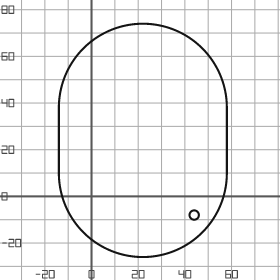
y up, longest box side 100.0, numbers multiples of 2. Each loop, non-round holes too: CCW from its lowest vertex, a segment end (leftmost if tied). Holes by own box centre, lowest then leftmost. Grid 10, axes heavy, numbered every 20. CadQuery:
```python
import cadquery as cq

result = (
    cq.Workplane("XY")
    .moveTo(-14.0, 10.0)
    .threePointArc((22.0, -26.0), (58.0, 10.0))
    .lineTo(58.0, 38.0)
    .threePointArc((22.0, 74.0), (-14.0, 38.0))
    .close()
    .moveTo(44.0, -8.0)
    .circle(2.0)
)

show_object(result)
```